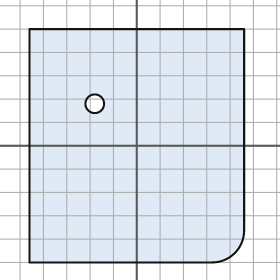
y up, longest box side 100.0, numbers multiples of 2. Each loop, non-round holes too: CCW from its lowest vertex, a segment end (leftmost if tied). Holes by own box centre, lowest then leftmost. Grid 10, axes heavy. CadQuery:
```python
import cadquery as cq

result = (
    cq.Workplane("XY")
    .moveTo(-46.0, -50.0)
    .lineTo(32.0, -50.0)
    .threePointArc((42.0, -46.0), (46.0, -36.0))
    .lineTo(46.0, 50.0)
    .lineTo(-46.0, 50.0)
    .close()
    .moveTo(-18.0, 18.0)
    .circle(4.0)
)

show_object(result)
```